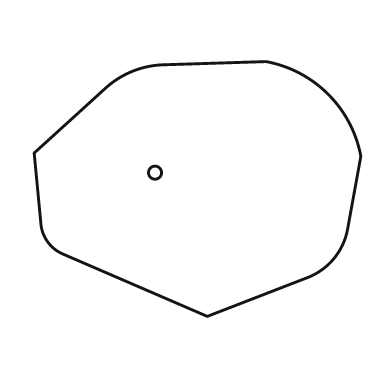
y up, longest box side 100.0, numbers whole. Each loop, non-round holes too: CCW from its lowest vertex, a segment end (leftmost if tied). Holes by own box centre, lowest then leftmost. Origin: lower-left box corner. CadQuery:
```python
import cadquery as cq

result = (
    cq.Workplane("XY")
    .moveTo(53.0, 0.0)
    .lineTo(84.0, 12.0)
    .threePointArc((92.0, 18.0), (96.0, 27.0))
    .lineTo(100.0, 49.0)
    .threePointArc((90.0, 68.0), (71.0, 78.0))
    .lineTo(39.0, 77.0)
    .threePointArc((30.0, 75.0), (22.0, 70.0))
    .lineTo(0.0, 50.0)
    .lineTo(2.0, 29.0)
    .threePointArc((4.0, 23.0), (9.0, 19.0))
    .close()
    .moveTo(37.0, 44.0)
    .circle(2.0)
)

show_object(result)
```